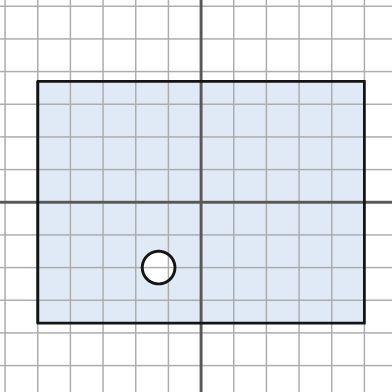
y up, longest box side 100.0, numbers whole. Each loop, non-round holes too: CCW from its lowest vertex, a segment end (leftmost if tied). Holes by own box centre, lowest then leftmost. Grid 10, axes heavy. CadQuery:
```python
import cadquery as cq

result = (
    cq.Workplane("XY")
    .moveTo(-50.0, -37.0)
    .lineTo(50.0, -37.0)
    .lineTo(50.0, 37.0)
    .lineTo(-50.0, 37.0)
    .close()
    .moveTo(-13.0, -20.0)
    .circle(5.0)
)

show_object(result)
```